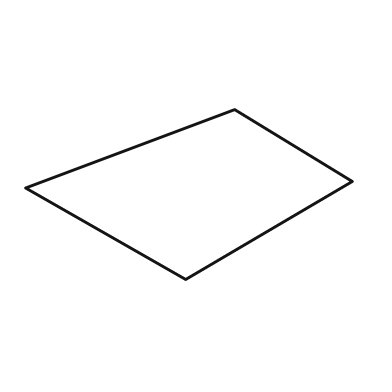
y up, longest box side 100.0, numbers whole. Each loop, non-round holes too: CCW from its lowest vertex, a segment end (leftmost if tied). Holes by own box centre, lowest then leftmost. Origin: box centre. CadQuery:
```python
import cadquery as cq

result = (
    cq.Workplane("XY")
    .moveTo(-1.0, -26.0)
    .lineTo(50.0, 4.0)
    .lineTo(14.0, 26.0)
    .lineTo(-50.0, 2.0)
    .close()
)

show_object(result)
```